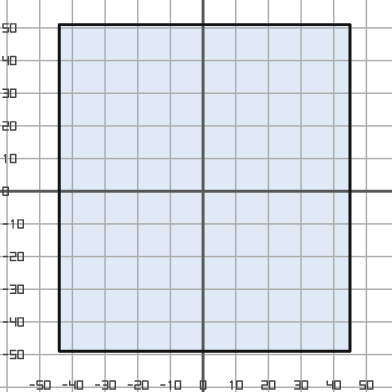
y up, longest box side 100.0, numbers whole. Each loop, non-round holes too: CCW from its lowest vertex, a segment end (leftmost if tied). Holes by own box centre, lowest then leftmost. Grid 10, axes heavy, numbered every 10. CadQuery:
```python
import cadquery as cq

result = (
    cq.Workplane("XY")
    .moveTo(-44.0, -49.0)
    .lineTo(45.0, -49.0)
    .lineTo(45.0, 51.0)
    .lineTo(-44.0, 51.0)
    .close()
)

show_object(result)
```